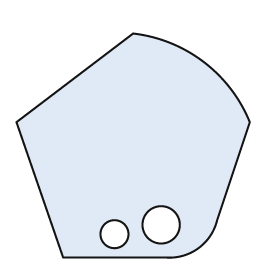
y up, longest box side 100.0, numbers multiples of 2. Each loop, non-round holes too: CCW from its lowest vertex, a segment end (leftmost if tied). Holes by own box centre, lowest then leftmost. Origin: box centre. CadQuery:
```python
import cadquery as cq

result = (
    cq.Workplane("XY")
    .moveTo(-30.0, -48.0)
    .lineTo(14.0, -48.0)
    .threePointArc((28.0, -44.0), (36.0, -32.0))
    .lineTo(50.0, 10.0)
    .threePointArc((30.0, 36.0), (0.0, 48.0))
    .lineTo(-50.0, 10.0)
    .close()
    .moveTo(-8.0, -38.0)
    .circle(6.0)
    .moveTo(12.0, -34.0)
    .circle(8.0)
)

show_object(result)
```